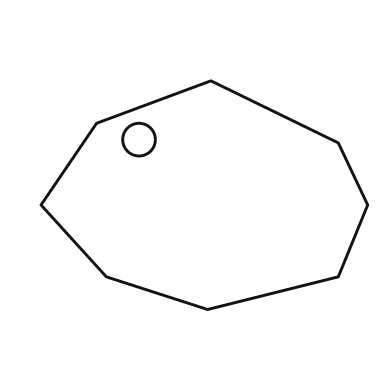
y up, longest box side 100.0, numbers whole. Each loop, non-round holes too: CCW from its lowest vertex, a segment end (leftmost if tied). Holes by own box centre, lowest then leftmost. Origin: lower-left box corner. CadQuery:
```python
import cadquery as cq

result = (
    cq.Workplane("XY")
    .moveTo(51.0, 0.0)
    .lineTo(91.0, 10.0)
    .lineTo(100.0, 32.0)
    .lineTo(91.0, 51.0)
    .lineTo(52.0, 70.0)
    .lineTo(17.0, 57.0)
    .lineTo(0.0, 32.0)
    .lineTo(20.0, 10.0)
    .close()
    .moveTo(30.0, 52.0)
    .circle(5.0)
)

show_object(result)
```